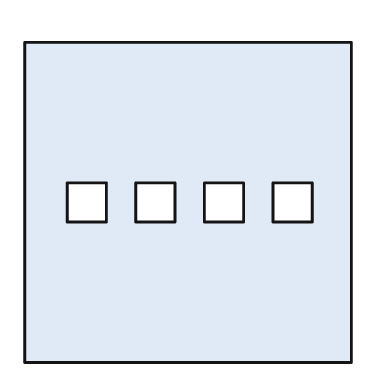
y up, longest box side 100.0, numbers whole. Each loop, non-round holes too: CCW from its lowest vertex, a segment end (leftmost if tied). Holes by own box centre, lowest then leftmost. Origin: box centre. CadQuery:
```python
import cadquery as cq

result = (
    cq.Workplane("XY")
    .moveTo(-50.0, -49.0)
    .lineTo(50.0, -49.0)
    .lineTo(50.0, 49.0)
    .lineTo(-50.0, 49.0)
    .close()
    .moveTo(-37.0, -6.0)
    .lineTo(-25.0, -6.0)
    .lineTo(-25.0, 6.0)
    .lineTo(-37.0, 6.0)
    .close()
    .moveTo(-16.0, -6.0)
    .lineTo(-4.0, -6.0)
    .lineTo(-4.0, 6.0)
    .lineTo(-16.0, 6.0)
    .close()
    .moveTo(5.0, -6.0)
    .lineTo(17.0, -6.0)
    .lineTo(17.0, 6.0)
    .lineTo(5.0, 6.0)
    .close()
    .moveTo(26.0, -6.0)
    .lineTo(38.0, -6.0)
    .lineTo(38.0, 6.0)
    .lineTo(26.0, 6.0)
    .close()
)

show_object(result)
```